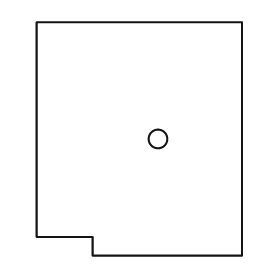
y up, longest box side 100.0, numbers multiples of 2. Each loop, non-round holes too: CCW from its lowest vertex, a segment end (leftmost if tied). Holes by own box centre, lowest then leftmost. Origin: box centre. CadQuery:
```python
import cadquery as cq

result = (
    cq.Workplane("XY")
    .moveTo(-20.0, -50.0)
    .lineTo(44.0, -50.0)
    .lineTo(44.0, 50.0)
    .lineTo(-44.0, 50.0)
    .lineTo(-44.0, -42.0)
    .lineTo(-20.0, -42.0)
    .close()
    .moveTo(8.0, 0.0)
    .circle(4.0)
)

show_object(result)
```